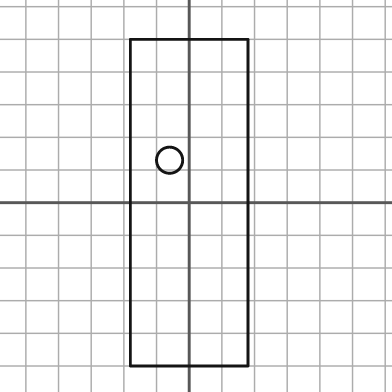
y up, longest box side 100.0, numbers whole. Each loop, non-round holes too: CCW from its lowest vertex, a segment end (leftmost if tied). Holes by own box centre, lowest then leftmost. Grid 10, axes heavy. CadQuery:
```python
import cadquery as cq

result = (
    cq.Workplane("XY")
    .moveTo(-18.0, -50.0)
    .lineTo(18.0, -50.0)
    .lineTo(18.0, 50.0)
    .lineTo(-18.0, 50.0)
    .close()
    .moveTo(-6.0, 13.0)
    .circle(4.0)
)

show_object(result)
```